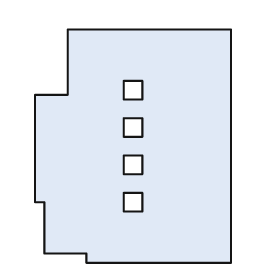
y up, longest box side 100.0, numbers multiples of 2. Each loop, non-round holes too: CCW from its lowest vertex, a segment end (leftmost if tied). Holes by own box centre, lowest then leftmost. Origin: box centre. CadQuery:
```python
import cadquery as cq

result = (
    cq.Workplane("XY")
    .moveTo(-20.0, -50.0)
    .lineTo(42.0, -50.0)
    .lineTo(42.0, 50.0)
    .lineTo(-28.0, 50.0)
    .lineTo(-28.0, 22.0)
    .lineTo(-42.0, 22.0)
    .lineTo(-42.0, -24.0)
    .lineTo(-38.0, -24.0)
    .lineTo(-38.0, -46.0)
    .lineTo(-20.0, -46.0)
    .close()
    .moveTo(-4.0, -28.0)
    .lineTo(4.0, -28.0)
    .lineTo(4.0, -20.0)
    .lineTo(-4.0, -20.0)
    .close()
    .moveTo(-4.0, -12.0)
    .lineTo(4.0, -12.0)
    .lineTo(4.0, -4.0)
    .lineTo(-4.0, -4.0)
    .close()
    .moveTo(-4.0, 4.0)
    .lineTo(4.0, 4.0)
    .lineTo(4.0, 12.0)
    .lineTo(-4.0, 12.0)
    .close()
    .moveTo(-4.0, 20.0)
    .lineTo(4.0, 20.0)
    .lineTo(4.0, 28.0)
    .lineTo(-4.0, 28.0)
    .close()
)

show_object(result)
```